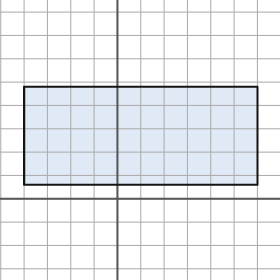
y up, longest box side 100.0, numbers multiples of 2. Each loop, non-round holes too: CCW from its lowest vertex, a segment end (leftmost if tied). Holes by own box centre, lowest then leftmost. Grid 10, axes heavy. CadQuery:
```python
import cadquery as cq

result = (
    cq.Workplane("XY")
    .moveTo(-40.0, 6.0)
    .lineTo(60.0, 6.0)
    .lineTo(60.0, 48.0)
    .lineTo(-40.0, 48.0)
    .close()
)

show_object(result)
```